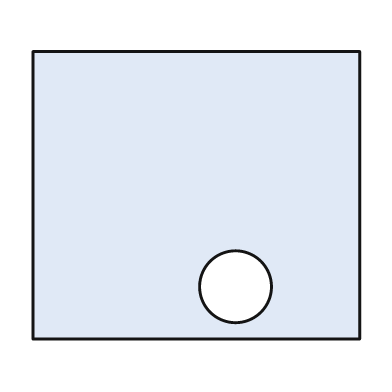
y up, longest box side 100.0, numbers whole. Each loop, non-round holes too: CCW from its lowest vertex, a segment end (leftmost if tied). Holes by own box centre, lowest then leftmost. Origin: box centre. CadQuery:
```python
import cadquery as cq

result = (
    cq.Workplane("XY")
    .moveTo(-50.0, -44.0)
    .lineTo(50.0, -44.0)
    .lineTo(50.0, 44.0)
    .lineTo(-50.0, 44.0)
    .close()
    .moveTo(12.0, -28.0)
    .circle(11.0)
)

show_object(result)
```